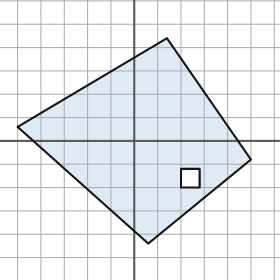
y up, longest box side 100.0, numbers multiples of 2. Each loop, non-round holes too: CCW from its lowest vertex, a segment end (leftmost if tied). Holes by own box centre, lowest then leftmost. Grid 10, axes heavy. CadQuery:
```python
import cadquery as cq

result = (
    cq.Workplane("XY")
    .moveTo(6.0, -44.0)
    .lineTo(50.0, -8.0)
    .lineTo(14.0, 44.0)
    .lineTo(-50.0, 6.0)
    .close()
    .moveTo(20.0, -20.0)
    .lineTo(28.0, -20.0)
    .lineTo(28.0, -12.0)
    .lineTo(20.0, -12.0)
    .close()
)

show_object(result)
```